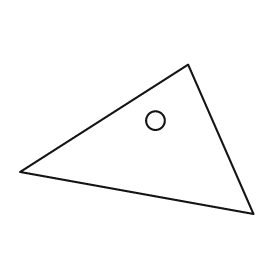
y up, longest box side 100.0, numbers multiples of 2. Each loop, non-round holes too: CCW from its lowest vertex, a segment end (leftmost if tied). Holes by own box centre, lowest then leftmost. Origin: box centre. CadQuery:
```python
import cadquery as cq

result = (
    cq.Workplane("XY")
    .moveTo(50.0, -32.0)
    .lineTo(22.0, 32.0)
    .lineTo(-50.0, -14.0)
    .close()
    .moveTo(8.0, 8.0)
    .circle(4.0)
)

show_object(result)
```